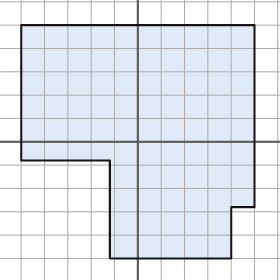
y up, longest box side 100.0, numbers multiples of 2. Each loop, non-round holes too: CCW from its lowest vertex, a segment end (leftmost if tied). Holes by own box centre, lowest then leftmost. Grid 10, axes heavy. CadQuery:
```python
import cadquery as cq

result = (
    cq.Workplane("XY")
    .moveTo(-12.0, -50.0)
    .lineTo(40.0, -50.0)
    .lineTo(40.0, -28.0)
    .lineTo(50.0, -28.0)
    .lineTo(50.0, 50.0)
    .lineTo(-50.0, 50.0)
    .lineTo(-50.0, -8.0)
    .lineTo(-12.0, -8.0)
    .close()
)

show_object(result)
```